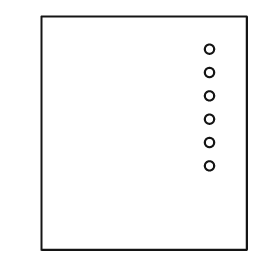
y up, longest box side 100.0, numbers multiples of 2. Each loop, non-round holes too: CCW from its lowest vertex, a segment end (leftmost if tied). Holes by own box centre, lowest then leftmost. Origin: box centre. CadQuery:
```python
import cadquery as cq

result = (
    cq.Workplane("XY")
    .moveTo(-44.0, -50.0)
    .lineTo(44.0, -50.0)
    .lineTo(44.0, 50.0)
    .lineTo(-44.0, 50.0)
    .close()
    .moveTo(28.0, -14.0)
    .circle(2.0)
    .moveTo(28.0, -4.0)
    .circle(2.0)
    .moveTo(28.0, 6.0)
    .circle(2.0)
    .moveTo(28.0, 16.0)
    .circle(2.0)
    .moveTo(28.0, 26.0)
    .circle(2.0)
    .moveTo(28.0, 36.0)
    .circle(2.0)
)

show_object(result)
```